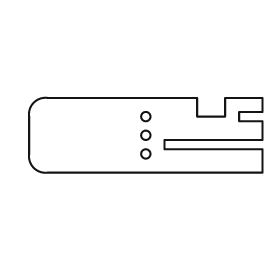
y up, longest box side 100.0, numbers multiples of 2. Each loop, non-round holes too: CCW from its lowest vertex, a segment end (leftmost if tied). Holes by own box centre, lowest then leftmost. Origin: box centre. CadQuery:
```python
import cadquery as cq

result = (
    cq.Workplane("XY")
    .moveTo(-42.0, -16.0)
    .lineTo(50.0, -16.0)
    .lineTo(50.0, -6.0)
    .lineTo(8.0, -6.0)
    .lineTo(8.0, -2.0)
    .lineTo(50.0, -2.0)
    .lineTo(50.0, 6.0)
    .lineTo(40.0, 6.0)
    .lineTo(40.0, 10.0)
    .lineTo(50.0, 10.0)
    .lineTo(50.0, 16.0)
    .lineTo(34.0, 16.0)
    .lineTo(34.0, 8.0)
    .lineTo(22.0, 8.0)
    .lineTo(22.0, 16.0)
    .lineTo(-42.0, 16.0)
    .threePointArc((-48.0, 14.0), (-50.0, 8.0))
    .lineTo(-50.0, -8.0)
    .threePointArc((-48.0, -14.0), (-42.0, -16.0))
    .close()
    .moveTo(0.0, -8.0)
    .circle(2.0)
    .moveTo(0.0, 0.0)
    .circle(2.0)
    .moveTo(0.0, 8.0)
    .circle(2.0)
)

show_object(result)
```